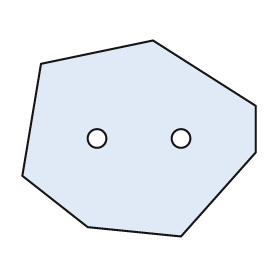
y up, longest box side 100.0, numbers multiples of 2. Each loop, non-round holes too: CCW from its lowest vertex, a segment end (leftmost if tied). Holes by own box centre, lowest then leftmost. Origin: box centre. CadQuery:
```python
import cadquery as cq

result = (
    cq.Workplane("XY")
    .moveTo(18.0, -42.0)
    .lineTo(50.0, -6.0)
    .lineTo(50.0, 14.0)
    .lineTo(6.0, 42.0)
    .lineTo(-42.0, 32.0)
    .lineTo(-50.0, -16.0)
    .lineTo(-22.0, -38.0)
    .close()
    .moveTo(-18.0, 0.0)
    .circle(4.0)
    .moveTo(18.0, 0.0)
    .circle(4.0)
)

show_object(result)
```